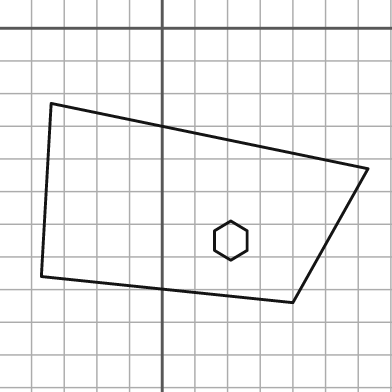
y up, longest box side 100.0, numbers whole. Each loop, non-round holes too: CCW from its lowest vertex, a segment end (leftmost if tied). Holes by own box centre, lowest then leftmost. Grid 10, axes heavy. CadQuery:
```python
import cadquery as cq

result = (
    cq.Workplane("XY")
    .moveTo(40.0, -84.0)
    .lineTo(63.0, -43.0)
    .lineTo(-34.0, -23.0)
    .lineTo(-37.0, -76.0)
    .close()
    .moveTo(21.0, -71.0)
    .lineTo(26.0, -68.0)
    .lineTo(26.0, -62.0)
    .lineTo(21.0, -59.0)
    .lineTo(16.0, -62.0)
    .lineTo(16.0, -68.0)
    .close()
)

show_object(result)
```